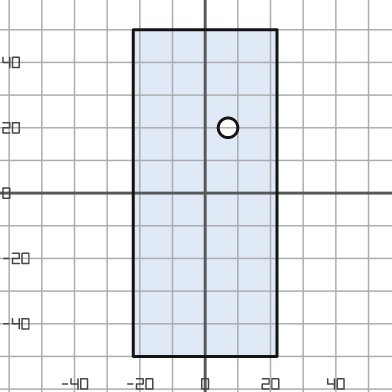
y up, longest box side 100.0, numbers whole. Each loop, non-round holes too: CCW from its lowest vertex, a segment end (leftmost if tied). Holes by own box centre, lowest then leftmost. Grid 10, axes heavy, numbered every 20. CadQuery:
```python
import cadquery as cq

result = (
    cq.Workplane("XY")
    .moveTo(-22.0, -50.0)
    .lineTo(22.0, -50.0)
    .lineTo(22.0, 50.0)
    .lineTo(-22.0, 50.0)
    .close()
    .moveTo(7.0, 20.0)
    .circle(3.0)
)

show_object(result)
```